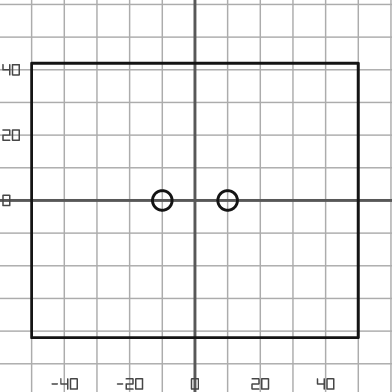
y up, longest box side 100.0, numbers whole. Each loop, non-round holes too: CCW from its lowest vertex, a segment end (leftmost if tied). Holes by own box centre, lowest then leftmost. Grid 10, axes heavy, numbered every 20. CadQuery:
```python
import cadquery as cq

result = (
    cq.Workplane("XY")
    .moveTo(-50.0, -42.0)
    .lineTo(50.0, -42.0)
    .lineTo(50.0, 42.0)
    .lineTo(-50.0, 42.0)
    .close()
    .moveTo(-10.0, 0.0)
    .circle(3.0)
    .moveTo(10.0, 0.0)
    .circle(3.0)
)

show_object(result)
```